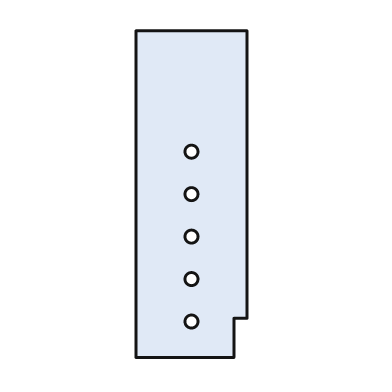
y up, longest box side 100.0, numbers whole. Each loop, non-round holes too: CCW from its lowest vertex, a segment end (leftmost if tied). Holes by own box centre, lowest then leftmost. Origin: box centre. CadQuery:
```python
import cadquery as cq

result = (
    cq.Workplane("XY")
    .moveTo(-17.0, -50.0)
    .lineTo(13.0, -50.0)
    .lineTo(13.0, -38.0)
    .lineTo(17.0, -38.0)
    .lineTo(17.0, 50.0)
    .lineTo(-17.0, 50.0)
    .close()
    .moveTo(0.0, -39.0)
    .circle(2.0)
    .moveTo(0.0, -26.0)
    .circle(2.0)
    .moveTo(0.0, -13.0)
    .circle(2.0)
    .moveTo(0.0, 0.0)
    .circle(2.0)
    .moveTo(0.0, 13.0)
    .circle(2.0)
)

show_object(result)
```